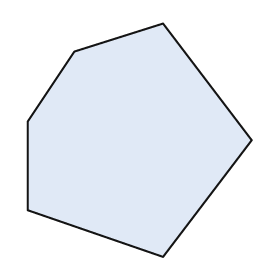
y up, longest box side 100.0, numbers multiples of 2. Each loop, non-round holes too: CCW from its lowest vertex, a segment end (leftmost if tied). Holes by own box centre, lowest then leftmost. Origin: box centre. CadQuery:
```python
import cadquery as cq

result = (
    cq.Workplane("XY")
    .moveTo(10.0, -50.0)
    .lineTo(48.0, 0.0)
    .lineTo(10.0, 50.0)
    .lineTo(-28.0, 38.0)
    .lineTo(-48.0, 8.0)
    .lineTo(-48.0, -30.0)
    .close()
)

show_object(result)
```